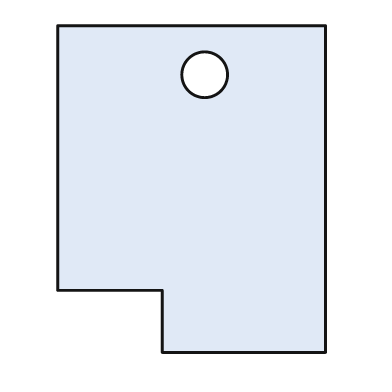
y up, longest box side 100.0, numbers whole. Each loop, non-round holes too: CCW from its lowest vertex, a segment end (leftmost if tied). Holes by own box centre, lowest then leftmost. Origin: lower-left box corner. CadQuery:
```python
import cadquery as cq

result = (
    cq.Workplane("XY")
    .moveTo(32.0, 0.0)
    .lineTo(82.0, 0.0)
    .lineTo(82.0, 100.0)
    .lineTo(0.0, 100.0)
    .lineTo(0.0, 19.0)
    .lineTo(32.0, 19.0)
    .close()
    .moveTo(45.0, 85.0)
    .circle(7.0)
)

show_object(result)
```